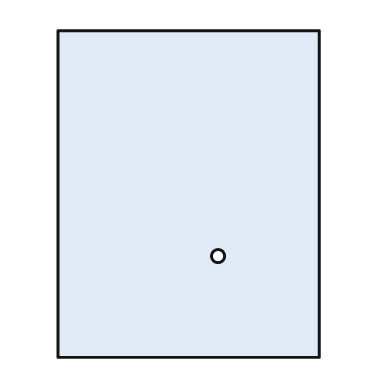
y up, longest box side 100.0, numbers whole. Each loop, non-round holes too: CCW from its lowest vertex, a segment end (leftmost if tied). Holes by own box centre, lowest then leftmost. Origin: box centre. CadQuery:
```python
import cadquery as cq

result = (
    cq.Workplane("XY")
    .moveTo(-40.0, -50.0)
    .lineTo(40.0, -50.0)
    .lineTo(40.0, 50.0)
    .lineTo(-40.0, 50.0)
    .close()
    .moveTo(9.0, -19.0)
    .circle(2.0)
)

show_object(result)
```